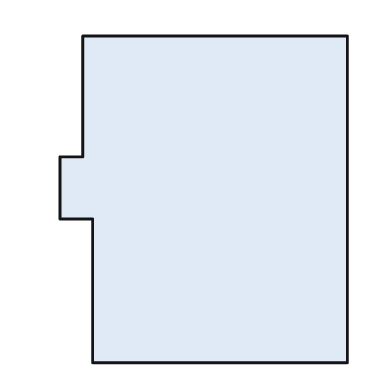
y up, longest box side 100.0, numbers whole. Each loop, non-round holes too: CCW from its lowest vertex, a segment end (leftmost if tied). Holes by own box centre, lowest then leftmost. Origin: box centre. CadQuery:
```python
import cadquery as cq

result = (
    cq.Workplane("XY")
    .moveTo(-34.0, -50.0)
    .lineTo(44.0, -50.0)
    .lineTo(44.0, 50.0)
    .lineTo(-37.0, 50.0)
    .lineTo(-37.0, 13.0)
    .lineTo(-44.0, 13.0)
    .lineTo(-44.0, -6.0)
    .lineTo(-34.0, -6.0)
    .close()
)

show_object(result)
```